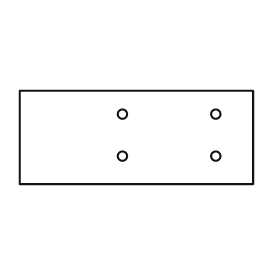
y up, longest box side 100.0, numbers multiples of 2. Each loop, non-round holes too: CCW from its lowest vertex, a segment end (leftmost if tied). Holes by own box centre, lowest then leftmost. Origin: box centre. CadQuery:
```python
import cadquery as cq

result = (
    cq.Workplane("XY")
    .moveTo(-50.0, -20.0)
    .lineTo(50.0, -20.0)
    .lineTo(50.0, 20.0)
    .lineTo(-50.0, 20.0)
    .close()
    .moveTo(-6.0, -8.0)
    .circle(2.0)
    .moveTo(34.0, -8.0)
    .circle(2.0)
    .moveTo(-6.0, 10.0)
    .circle(2.0)
    .moveTo(34.0, 10.0)
    .circle(2.0)
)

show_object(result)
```